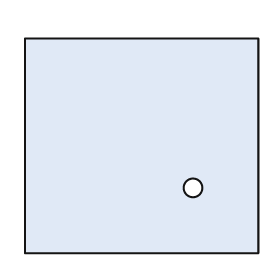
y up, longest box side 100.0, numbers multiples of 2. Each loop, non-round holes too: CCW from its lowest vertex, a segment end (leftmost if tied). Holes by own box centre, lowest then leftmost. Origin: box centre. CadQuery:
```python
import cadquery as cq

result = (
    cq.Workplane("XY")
    .moveTo(-50.0, -46.0)
    .lineTo(50.0, -46.0)
    .lineTo(50.0, 46.0)
    .lineTo(-50.0, 46.0)
    .close()
    .moveTo(22.0, -18.0)
    .circle(4.0)
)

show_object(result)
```